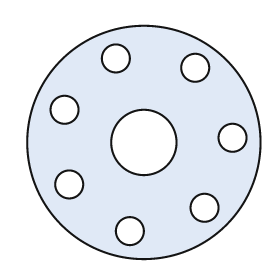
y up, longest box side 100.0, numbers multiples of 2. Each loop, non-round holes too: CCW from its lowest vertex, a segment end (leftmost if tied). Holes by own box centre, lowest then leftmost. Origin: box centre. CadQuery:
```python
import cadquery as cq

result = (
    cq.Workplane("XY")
    .moveTo(0.0, 0.0)
    .circle(50.0)
    .moveTo(-6.0, -38.0)
    .circle(6.0)
    .moveTo(26.0, -28.0)
    .circle(6.0)
    .moveTo(-32.0, -18.0)
    .circle(6.0)
    .moveTo(0.0, 0.0)
    .circle(14.0)
    .moveTo(38.0, 2.0)
    .circle(6.0)
    .moveTo(-34.0, 14.0)
    .circle(6.0)
    .moveTo(22.0, 32.0)
    .circle(6.0)
    .moveTo(-12.0, 36.0)
    .circle(6.0)
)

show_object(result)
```